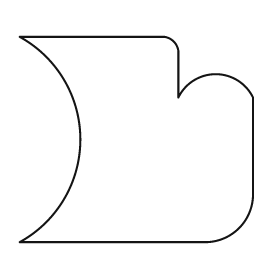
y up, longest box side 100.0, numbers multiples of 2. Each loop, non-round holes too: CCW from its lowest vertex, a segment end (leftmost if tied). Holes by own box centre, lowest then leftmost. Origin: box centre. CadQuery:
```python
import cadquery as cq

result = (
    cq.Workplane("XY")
    .moveTo(-50.0, -44.0)
    .lineTo(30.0, -44.0)
    .threePointArc((44.0, -38.0), (50.0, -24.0))
    .lineTo(50.0, 18.0)
    .threePointArc((34.0, 28.0), (18.0, 18.0))
    .lineTo(18.0, 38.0)
    .threePointArc((16.0, 42.0), (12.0, 44.0))
    .lineTo(-50.0, 44.0)
    .threePointArc((-24.0, 0.0), (-50.0, -44.0))
    .close()
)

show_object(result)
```